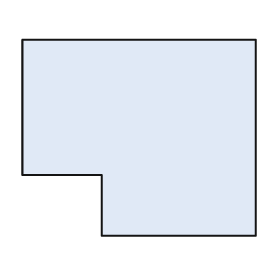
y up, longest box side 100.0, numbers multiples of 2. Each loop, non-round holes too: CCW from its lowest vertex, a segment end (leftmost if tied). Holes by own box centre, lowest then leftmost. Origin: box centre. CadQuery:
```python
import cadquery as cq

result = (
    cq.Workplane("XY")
    .moveTo(-16.0, -42.0)
    .lineTo(50.0, -42.0)
    .lineTo(50.0, 42.0)
    .lineTo(-50.0, 42.0)
    .lineTo(-50.0, -16.0)
    .lineTo(-16.0, -16.0)
    .close()
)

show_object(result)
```